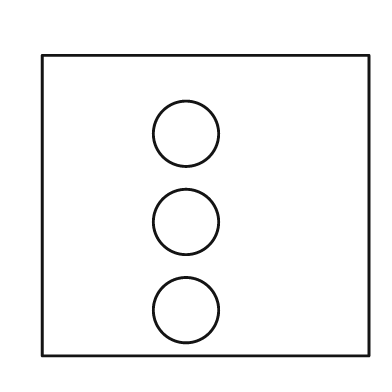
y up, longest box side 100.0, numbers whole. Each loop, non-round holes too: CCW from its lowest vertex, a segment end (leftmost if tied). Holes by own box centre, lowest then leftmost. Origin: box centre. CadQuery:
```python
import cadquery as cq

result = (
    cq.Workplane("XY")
    .moveTo(-50.0, -46.0)
    .lineTo(50.0, -46.0)
    .lineTo(50.0, 46.0)
    .lineTo(-50.0, 46.0)
    .close()
    .moveTo(-6.0, -32.0)
    .circle(10.0)
    .moveTo(-6.0, -5.0)
    .circle(10.0)
    .moveTo(-6.0, 22.0)
    .circle(10.0)
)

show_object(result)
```